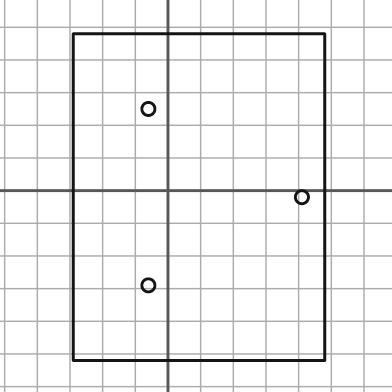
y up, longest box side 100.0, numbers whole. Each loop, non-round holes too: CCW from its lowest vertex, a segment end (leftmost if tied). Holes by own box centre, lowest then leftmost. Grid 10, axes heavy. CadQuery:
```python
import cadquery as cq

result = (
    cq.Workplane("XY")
    .moveTo(-29.0, -52.0)
    .lineTo(48.0, -52.0)
    .lineTo(48.0, 48.0)
    .lineTo(-29.0, 48.0)
    .close()
    .moveTo(-6.0, -29.0)
    .circle(2.0)
    .moveTo(41.0, -2.0)
    .circle(2.0)
    .moveTo(-6.0, 25.0)
    .circle(2.0)
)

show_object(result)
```